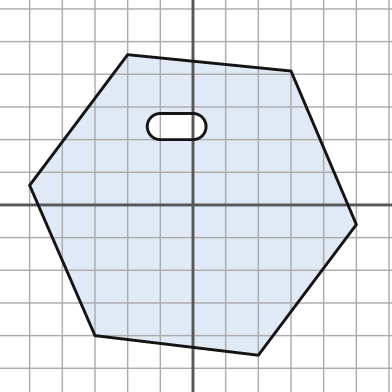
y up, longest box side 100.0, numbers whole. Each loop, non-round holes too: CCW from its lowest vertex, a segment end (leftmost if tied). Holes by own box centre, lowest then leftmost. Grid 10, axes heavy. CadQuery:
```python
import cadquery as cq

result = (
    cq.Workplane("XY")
    .moveTo(20.0, -46.0)
    .lineTo(50.0, -6.0)
    .lineTo(30.0, 41.0)
    .lineTo(-20.0, 46.0)
    .lineTo(-50.0, 6.0)
    .lineTo(-30.0, -40.0)
    .close()
    .moveTo(-10.0, 20.0)
    .lineTo(0.0, 20.0)
    .threePointArc((4.0, 24.0), (0.0, 28.0))
    .lineTo(-10.0, 28.0)
    .threePointArc((-14.0, 24.0), (-10.0, 20.0))
    .close()
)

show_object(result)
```